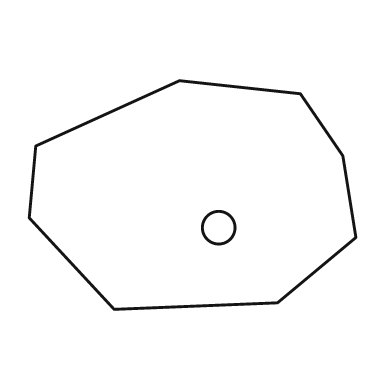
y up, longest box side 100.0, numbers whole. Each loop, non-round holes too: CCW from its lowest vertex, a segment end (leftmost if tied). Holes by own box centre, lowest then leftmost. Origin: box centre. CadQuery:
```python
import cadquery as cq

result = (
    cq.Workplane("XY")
    .moveTo(-24.0, -35.0)
    .lineTo(26.0, -33.0)
    .lineTo(50.0, -13.0)
    .lineTo(46.0, 12.0)
    .lineTo(33.0, 31.0)
    .lineTo(-4.0, 35.0)
    .lineTo(-48.0, 15.0)
    .lineTo(-50.0, -7.0)
    .close()
    .moveTo(8.0, -10.0)
    .circle(5.0)
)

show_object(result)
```